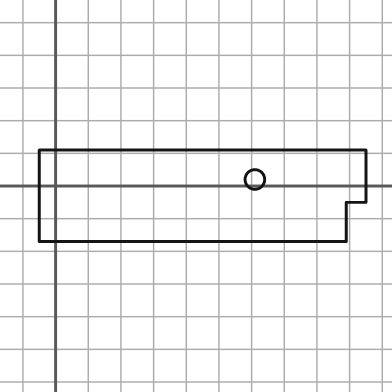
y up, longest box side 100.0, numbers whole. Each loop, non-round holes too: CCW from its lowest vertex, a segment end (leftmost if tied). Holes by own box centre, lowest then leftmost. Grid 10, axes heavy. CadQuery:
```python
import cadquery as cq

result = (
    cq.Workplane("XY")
    .moveTo(-5.0, -17.0)
    .lineTo(89.0, -17.0)
    .lineTo(89.0, -5.0)
    .lineTo(95.0, -5.0)
    .lineTo(95.0, 11.0)
    .lineTo(-5.0, 11.0)
    .close()
    .moveTo(61.0, 2.0)
    .circle(3.0)
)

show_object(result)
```